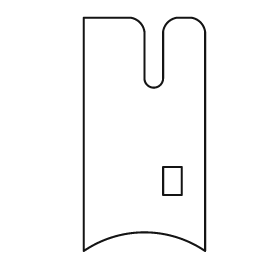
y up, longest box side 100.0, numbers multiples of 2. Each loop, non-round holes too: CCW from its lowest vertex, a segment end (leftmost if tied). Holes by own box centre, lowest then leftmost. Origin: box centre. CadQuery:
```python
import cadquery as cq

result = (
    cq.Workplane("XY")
    .moveTo(-26.0, -50.0)
    .threePointArc((0.0, -42.0), (26.0, -50.0))
    .lineTo(26.0, 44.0)
    .threePointArc((24.0, 48.0), (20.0, 50.0))
    .lineTo(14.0, 50.0)
    .threePointArc((10.0, 48.0), (8.0, 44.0))
    .lineTo(8.0, 24.0)
    .threePointArc((4.0, 20.0), (0.0, 24.0))
    .lineTo(0.0, 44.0)
    .threePointArc((-2.0, 48.0), (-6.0, 50.0))
    .lineTo(-26.0, 50.0)
    .close()
    .moveTo(8.0, -26.0)
    .lineTo(16.0, -26.0)
    .lineTo(16.0, -14.0)
    .lineTo(8.0, -14.0)
    .close()
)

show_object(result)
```